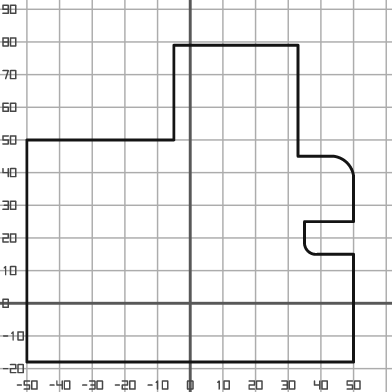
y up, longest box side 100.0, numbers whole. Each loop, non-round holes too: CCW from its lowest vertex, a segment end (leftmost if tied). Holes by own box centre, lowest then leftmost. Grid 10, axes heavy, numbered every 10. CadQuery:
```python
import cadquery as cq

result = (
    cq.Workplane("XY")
    .moveTo(-50.0, -18.0)
    .lineTo(50.0, -18.0)
    .lineTo(50.0, 15.0)
    .lineTo(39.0, 15.0)
    .threePointArc((36.0, 16.0), (35.0, 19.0))
    .lineTo(35.0, 25.0)
    .lineTo(50.0, 25.0)
    .lineTo(50.0, 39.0)
    .threePointArc((48.0, 43.0), (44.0, 45.0))
    .lineTo(33.0, 45.0)
    .lineTo(33.0, 79.0)
    .lineTo(-5.0, 79.0)
    .lineTo(-5.0, 50.0)
    .lineTo(-50.0, 50.0)
    .close()
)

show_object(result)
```